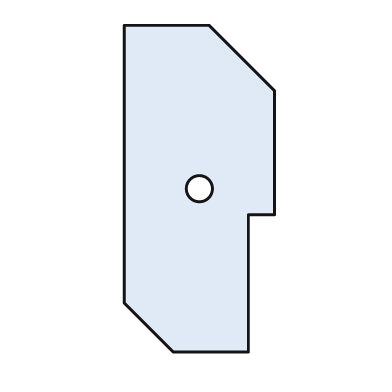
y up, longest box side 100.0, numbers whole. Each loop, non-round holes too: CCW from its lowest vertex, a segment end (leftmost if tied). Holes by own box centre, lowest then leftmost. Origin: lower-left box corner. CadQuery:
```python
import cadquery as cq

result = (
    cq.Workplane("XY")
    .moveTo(15.0, 0.0)
    .lineTo(38.0, 0.0)
    .lineTo(38.0, 42.0)
    .lineTo(46.0, 42.0)
    .lineTo(46.0, 80.0)
    .lineTo(26.0, 100.0)
    .lineTo(0.0, 100.0)
    .lineTo(0.0, 15.0)
    .close()
    .moveTo(23.0, 50.0)
    .circle(4.0)
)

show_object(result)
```